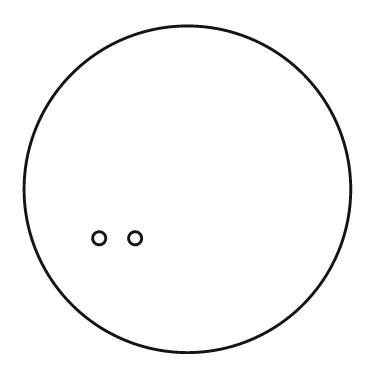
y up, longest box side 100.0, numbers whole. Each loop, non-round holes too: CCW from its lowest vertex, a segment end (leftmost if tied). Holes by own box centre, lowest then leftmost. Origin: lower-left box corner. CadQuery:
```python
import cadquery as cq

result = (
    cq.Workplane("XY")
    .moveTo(50.0, 50.0)
    .circle(50.0)
    .moveTo(23.0, 35.0)
    .circle(2.0)
    .moveTo(34.0, 35.0)
    .circle(2.0)
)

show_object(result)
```